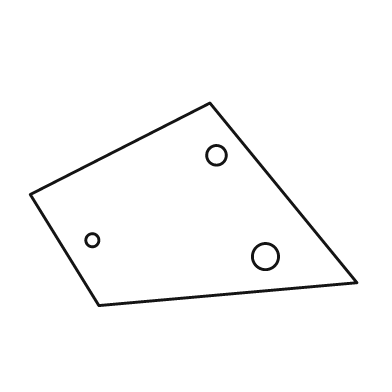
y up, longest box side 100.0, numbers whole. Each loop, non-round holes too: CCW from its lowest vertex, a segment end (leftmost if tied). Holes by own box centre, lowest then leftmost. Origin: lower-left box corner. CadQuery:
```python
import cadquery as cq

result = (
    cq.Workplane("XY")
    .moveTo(21.0, 0.0)
    .lineTo(100.0, 7.0)
    .lineTo(55.0, 62.0)
    .lineTo(0.0, 34.0)
    .close()
    .moveTo(72.0, 15.0)
    .circle(4.0)
    .moveTo(19.0, 20.0)
    .circle(2.0)
    .moveTo(57.0, 46.0)
    .circle(3.0)
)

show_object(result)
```